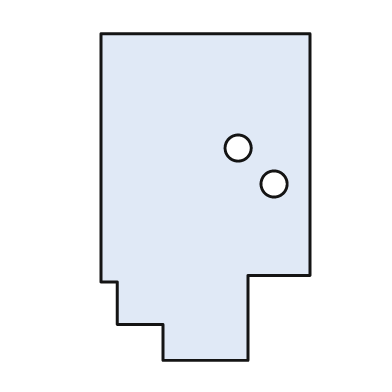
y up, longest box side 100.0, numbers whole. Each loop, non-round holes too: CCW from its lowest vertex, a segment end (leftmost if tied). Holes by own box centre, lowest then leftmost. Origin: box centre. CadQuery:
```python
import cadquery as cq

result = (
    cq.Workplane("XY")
    .moveTo(-13.0, -50.0)
    .lineTo(13.0, -50.0)
    .lineTo(13.0, -24.0)
    .lineTo(32.0, -24.0)
    .lineTo(32.0, 50.0)
    .lineTo(-32.0, 50.0)
    .lineTo(-32.0, -26.0)
    .lineTo(-27.0, -26.0)
    .lineTo(-27.0, -39.0)
    .lineTo(-13.0, -39.0)
    .close()
    .moveTo(21.0, 4.0)
    .circle(4.0)
    .moveTo(10.0, 15.0)
    .circle(4.0)
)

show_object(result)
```